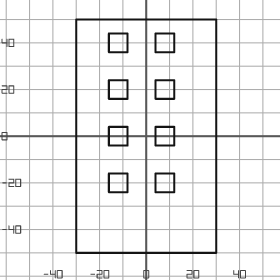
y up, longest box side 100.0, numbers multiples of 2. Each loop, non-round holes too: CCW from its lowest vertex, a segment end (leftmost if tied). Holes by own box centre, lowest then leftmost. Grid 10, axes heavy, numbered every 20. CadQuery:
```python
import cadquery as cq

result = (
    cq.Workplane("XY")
    .moveTo(-30.0, -50.0)
    .lineTo(30.0, -50.0)
    .lineTo(30.0, 50.0)
    .lineTo(-30.0, 50.0)
    .close()
    .moveTo(-16.0, -24.0)
    .lineTo(-8.0, -24.0)
    .lineTo(-8.0, -16.0)
    .lineTo(-16.0, -16.0)
    .close()
    .moveTo(4.0, -24.0)
    .lineTo(12.0, -24.0)
    .lineTo(12.0, -16.0)
    .lineTo(4.0, -16.0)
    .close()
    .moveTo(-16.0, -4.0)
    .lineTo(-8.0, -4.0)
    .lineTo(-8.0, 4.0)
    .lineTo(-16.0, 4.0)
    .close()
    .moveTo(4.0, -4.0)
    .lineTo(12.0, -4.0)
    .lineTo(12.0, 4.0)
    .lineTo(4.0, 4.0)
    .close()
    .moveTo(-16.0, 16.0)
    .lineTo(-8.0, 16.0)
    .lineTo(-8.0, 24.0)
    .lineTo(-16.0, 24.0)
    .close()
    .moveTo(4.0, 16.0)
    .lineTo(12.0, 16.0)
    .lineTo(12.0, 24.0)
    .lineTo(4.0, 24.0)
    .close()
    .moveTo(-16.0, 36.0)
    .lineTo(-8.0, 36.0)
    .lineTo(-8.0, 44.0)
    .lineTo(-16.0, 44.0)
    .close()
    .moveTo(4.0, 36.0)
    .lineTo(12.0, 36.0)
    .lineTo(12.0, 44.0)
    .lineTo(4.0, 44.0)
    .close()
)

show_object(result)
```